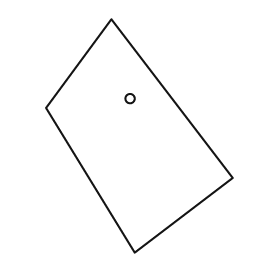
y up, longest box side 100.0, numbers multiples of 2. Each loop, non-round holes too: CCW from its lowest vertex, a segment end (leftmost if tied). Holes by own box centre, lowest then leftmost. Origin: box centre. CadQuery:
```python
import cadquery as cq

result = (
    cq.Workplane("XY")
    .moveTo(-2.0, -50.0)
    .lineTo(40.0, -18.0)
    .lineTo(-12.0, 50.0)
    .lineTo(-40.0, 12.0)
    .close()
    .moveTo(-4.0, 16.0)
    .circle(2.0)
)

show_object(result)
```